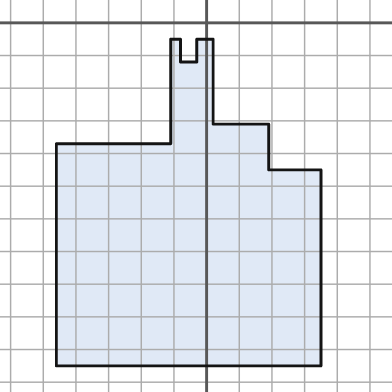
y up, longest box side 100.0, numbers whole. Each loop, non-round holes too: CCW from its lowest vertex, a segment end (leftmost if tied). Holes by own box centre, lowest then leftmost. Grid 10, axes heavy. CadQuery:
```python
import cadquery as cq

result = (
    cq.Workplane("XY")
    .moveTo(-46.0, -105.0)
    .lineTo(35.0, -105.0)
    .lineTo(35.0, -45.0)
    .lineTo(19.0, -45.0)
    .lineTo(19.0, -31.0)
    .lineTo(2.0, -31.0)
    .lineTo(2.0, -5.0)
    .lineTo(-3.0, -5.0)
    .lineTo(-3.0, -12.0)
    .lineTo(-8.0, -12.0)
    .lineTo(-8.0, -5.0)
    .lineTo(-11.0, -5.0)
    .lineTo(-11.0, -37.0)
    .lineTo(-46.0, -37.0)
    .close()
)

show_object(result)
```